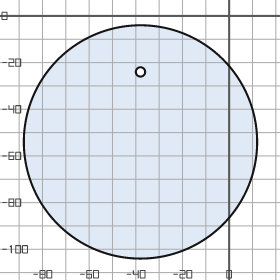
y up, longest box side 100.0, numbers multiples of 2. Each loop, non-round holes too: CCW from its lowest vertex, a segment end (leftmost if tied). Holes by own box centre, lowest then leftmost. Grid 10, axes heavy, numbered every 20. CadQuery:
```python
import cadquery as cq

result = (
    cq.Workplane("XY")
    .moveTo(-38.0, -54.0)
    .circle(50.0)
    .moveTo(-38.0, -24.0)
    .circle(2.0)
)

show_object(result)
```